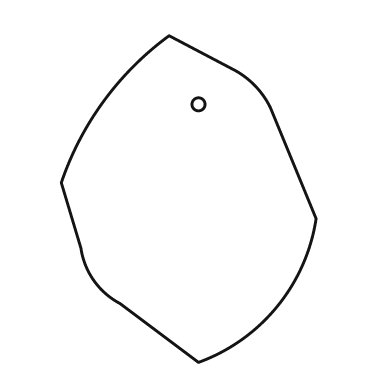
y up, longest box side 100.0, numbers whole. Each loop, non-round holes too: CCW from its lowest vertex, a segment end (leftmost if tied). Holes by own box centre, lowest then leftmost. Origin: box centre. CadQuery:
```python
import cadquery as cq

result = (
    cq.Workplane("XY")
    .moveTo(3.0, -50.0)
    .threePointArc((27.0, -33.0), (39.0, -6.0))
    .lineTo(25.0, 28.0)
    .threePointArc((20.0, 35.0), (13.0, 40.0))
    .lineTo(-6.0, 50.0)
    .threePointArc((-26.0, 30.0), (-39.0, 5.0))
    .lineTo(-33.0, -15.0)
    .threePointArc((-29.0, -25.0), (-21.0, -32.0))
    .close()
    .moveTo(3.0, 29.0)
    .circle(2.0)
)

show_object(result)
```